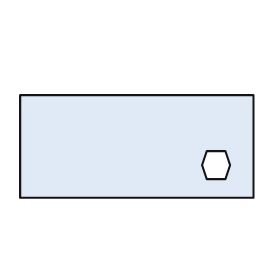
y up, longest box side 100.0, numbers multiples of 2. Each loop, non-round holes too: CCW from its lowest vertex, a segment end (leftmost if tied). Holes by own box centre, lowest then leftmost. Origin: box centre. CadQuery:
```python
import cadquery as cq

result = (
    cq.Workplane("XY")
    .moveTo(-50.0, -22.0)
    .lineTo(50.0, -22.0)
    .lineTo(50.0, 22.0)
    .lineTo(-50.0, 22.0)
    .close()
    .moveTo(30.0, -14.0)
    .lineTo(38.0, -14.0)
    .lineTo(40.0, -8.0)
    .lineTo(38.0, -2.0)
    .lineTo(30.0, -2.0)
    .lineTo(28.0, -8.0)
    .close()
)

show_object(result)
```